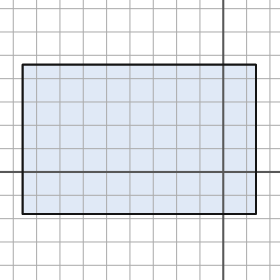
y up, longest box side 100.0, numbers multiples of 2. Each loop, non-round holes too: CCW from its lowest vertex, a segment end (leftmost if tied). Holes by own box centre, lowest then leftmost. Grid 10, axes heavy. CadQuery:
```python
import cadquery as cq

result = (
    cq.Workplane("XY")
    .moveTo(-86.0, -18.0)
    .lineTo(14.0, -18.0)
    .lineTo(14.0, 46.0)
    .lineTo(-86.0, 46.0)
    .close()
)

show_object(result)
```